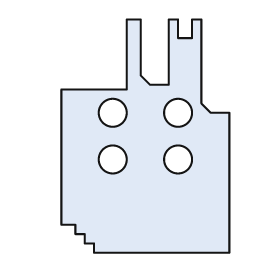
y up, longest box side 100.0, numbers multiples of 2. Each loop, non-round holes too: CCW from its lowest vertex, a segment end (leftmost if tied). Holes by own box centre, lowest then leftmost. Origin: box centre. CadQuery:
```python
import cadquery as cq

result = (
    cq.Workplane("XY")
    .moveTo(-22.0, -50.0)
    .lineTo(36.0, -50.0)
    .lineTo(36.0, 10.0)
    .lineTo(28.0, 10.0)
    .lineTo(24.0, 14.0)
    .lineTo(24.0, 50.0)
    .lineTo(20.0, 50.0)
    .lineTo(20.0, 42.0)
    .lineTo(14.0, 42.0)
    .lineTo(14.0, 50.0)
    .lineTo(10.0, 50.0)
    .lineTo(10.0, 22.0)
    .lineTo(2.0, 22.0)
    .lineTo(-2.0, 26.0)
    .lineTo(-2.0, 50.0)
    .lineTo(-8.0, 50.0)
    .lineTo(-8.0, 20.0)
    .lineTo(-36.0, 20.0)
    .lineTo(-36.0, -38.0)
    .lineTo(-30.0, -38.0)
    .lineTo(-30.0, -42.0)
    .lineTo(-26.0, -42.0)
    .lineTo(-26.0, -46.0)
    .lineTo(-22.0, -46.0)
    .close()
    .moveTo(-14.0, -10.0)
    .circle(6.0)
    .moveTo(14.0, -10.0)
    .circle(6.0)
    .moveTo(-14.0, 10.0)
    .circle(6.0)
    .moveTo(14.0, 10.0)
    .circle(6.0)
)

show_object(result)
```